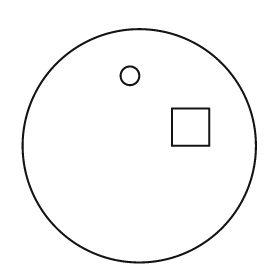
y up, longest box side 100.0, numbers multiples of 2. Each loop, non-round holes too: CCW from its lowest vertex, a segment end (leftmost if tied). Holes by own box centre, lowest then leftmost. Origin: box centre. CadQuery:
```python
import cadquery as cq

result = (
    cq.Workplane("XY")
    .moveTo(0.0, 0.0)
    .circle(50.0)
    .moveTo(14.0, 0.0)
    .lineTo(30.0, 0.0)
    .lineTo(30.0, 16.0)
    .lineTo(14.0, 16.0)
    .close()
    .moveTo(-4.0, 30.0)
    .circle(4.0)
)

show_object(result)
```